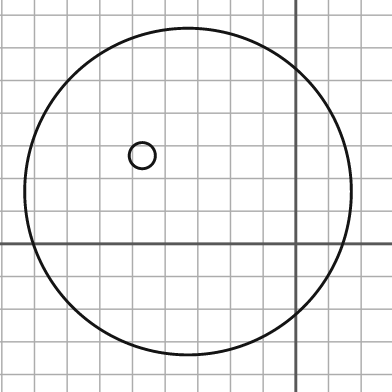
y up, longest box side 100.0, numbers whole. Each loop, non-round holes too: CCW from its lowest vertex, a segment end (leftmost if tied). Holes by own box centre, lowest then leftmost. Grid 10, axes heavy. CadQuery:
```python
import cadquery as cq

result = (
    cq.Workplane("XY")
    .moveTo(-33.0, 16.0)
    .circle(50.0)
    .moveTo(-47.0, 27.0)
    .circle(4.0)
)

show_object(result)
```